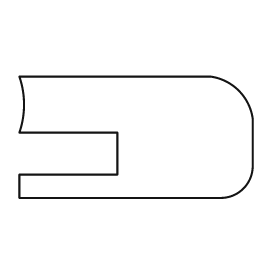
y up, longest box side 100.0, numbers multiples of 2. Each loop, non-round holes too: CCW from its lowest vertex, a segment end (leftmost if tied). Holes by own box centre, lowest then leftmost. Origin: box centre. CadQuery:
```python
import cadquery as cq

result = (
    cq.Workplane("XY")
    .moveTo(-50.0, -26.0)
    .lineTo(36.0, -26.0)
    .threePointArc((46.0, -22.0), (50.0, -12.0))
    .lineTo(50.0, 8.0)
    .threePointArc((44.0, 20.0), (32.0, 26.0))
    .lineTo(-50.0, 26.0)
    .threePointArc((-48.0, 14.0), (-50.0, 2.0))
    .lineTo(-8.0, 2.0)
    .lineTo(-8.0, -16.0)
    .lineTo(-50.0, -16.0)
    .close()
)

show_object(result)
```